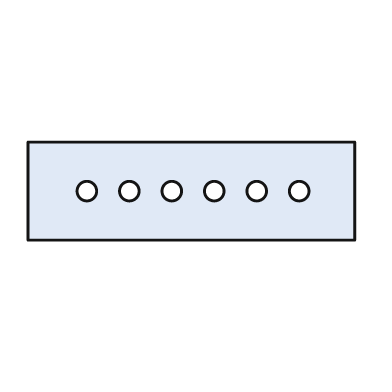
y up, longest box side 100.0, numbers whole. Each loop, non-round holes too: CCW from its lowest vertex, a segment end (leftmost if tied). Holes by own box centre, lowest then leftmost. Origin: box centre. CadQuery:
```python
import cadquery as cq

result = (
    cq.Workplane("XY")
    .moveTo(-50.0, -15.0)
    .lineTo(50.0, -15.0)
    .lineTo(50.0, 15.0)
    .lineTo(-50.0, 15.0)
    .close()
    .moveTo(-32.0, 0.0)
    .circle(3.0)
    .moveTo(-19.0, 0.0)
    .circle(3.0)
    .moveTo(-6.0, 0.0)
    .circle(3.0)
    .moveTo(7.0, 0.0)
    .circle(3.0)
    .moveTo(20.0, 0.0)
    .circle(3.0)
    .moveTo(33.0, 0.0)
    .circle(3.0)
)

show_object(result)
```